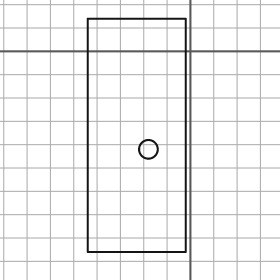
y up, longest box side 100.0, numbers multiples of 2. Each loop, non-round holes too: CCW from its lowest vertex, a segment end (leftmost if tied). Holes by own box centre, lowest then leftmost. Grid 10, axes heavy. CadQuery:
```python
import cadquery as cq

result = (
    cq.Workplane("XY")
    .moveTo(-44.0, -86.0)
    .lineTo(-2.0, -86.0)
    .lineTo(-2.0, 14.0)
    .lineTo(-44.0, 14.0)
    .close()
    .moveTo(-18.0, -42.0)
    .circle(4.0)
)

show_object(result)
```